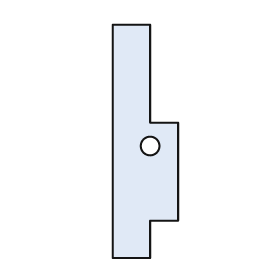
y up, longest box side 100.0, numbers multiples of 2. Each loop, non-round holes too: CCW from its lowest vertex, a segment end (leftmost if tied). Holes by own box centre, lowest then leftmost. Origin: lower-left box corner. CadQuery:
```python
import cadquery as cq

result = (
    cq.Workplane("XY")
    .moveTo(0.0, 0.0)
    .lineTo(16.0, 0.0)
    .lineTo(16.0, 16.0)
    .lineTo(28.0, 16.0)
    .lineTo(28.0, 58.0)
    .lineTo(16.0, 58.0)
    .lineTo(16.0, 100.0)
    .lineTo(0.0, 100.0)
    .close()
    .moveTo(16.0, 48.0)
    .circle(4.0)
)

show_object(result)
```